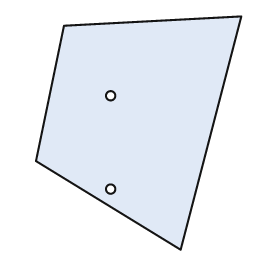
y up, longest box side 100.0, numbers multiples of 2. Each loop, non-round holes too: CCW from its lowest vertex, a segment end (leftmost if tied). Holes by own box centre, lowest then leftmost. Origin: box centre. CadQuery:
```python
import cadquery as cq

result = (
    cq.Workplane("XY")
    .moveTo(18.0, -50.0)
    .lineTo(44.0, 50.0)
    .lineTo(-32.0, 46.0)
    .lineTo(-44.0, -12.0)
    .close()
    .moveTo(-12.0, -24.0)
    .circle(2.0)
    .moveTo(-12.0, 16.0)
    .circle(2.0)
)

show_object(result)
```